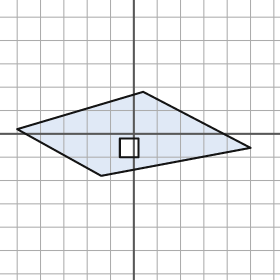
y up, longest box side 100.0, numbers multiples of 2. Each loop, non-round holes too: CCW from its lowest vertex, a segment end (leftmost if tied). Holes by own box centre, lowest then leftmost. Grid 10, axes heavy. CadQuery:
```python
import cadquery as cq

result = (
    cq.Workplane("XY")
    .moveTo(-14.0, -18.0)
    .lineTo(50.0, -6.0)
    .lineTo(4.0, 18.0)
    .lineTo(-50.0, 2.0)
    .close()
    .moveTo(-6.0, -10.0)
    .lineTo(2.0, -10.0)
    .lineTo(2.0, -2.0)
    .lineTo(-6.0, -2.0)
    .close()
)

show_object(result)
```